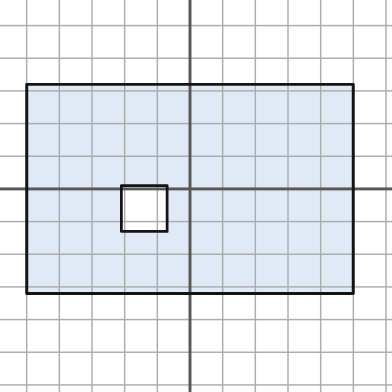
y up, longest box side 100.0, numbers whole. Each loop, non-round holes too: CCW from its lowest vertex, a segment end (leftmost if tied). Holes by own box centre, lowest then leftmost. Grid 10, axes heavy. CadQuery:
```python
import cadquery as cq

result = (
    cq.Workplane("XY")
    .moveTo(-50.0, -32.0)
    .lineTo(50.0, -32.0)
    .lineTo(50.0, 32.0)
    .lineTo(-50.0, 32.0)
    .close()
    .moveTo(-21.0, -13.0)
    .lineTo(-7.0, -13.0)
    .lineTo(-7.0, 1.0)
    .lineTo(-21.0, 1.0)
    .close()
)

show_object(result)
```